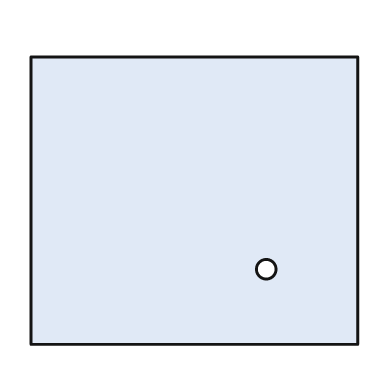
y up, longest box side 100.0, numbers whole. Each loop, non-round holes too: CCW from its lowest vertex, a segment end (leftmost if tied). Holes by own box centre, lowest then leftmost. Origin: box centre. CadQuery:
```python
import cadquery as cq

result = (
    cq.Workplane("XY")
    .moveTo(-50.0, -44.0)
    .lineTo(50.0, -44.0)
    .lineTo(50.0, 44.0)
    .lineTo(-50.0, 44.0)
    .close()
    .moveTo(22.0, -21.0)
    .circle(3.0)
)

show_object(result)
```